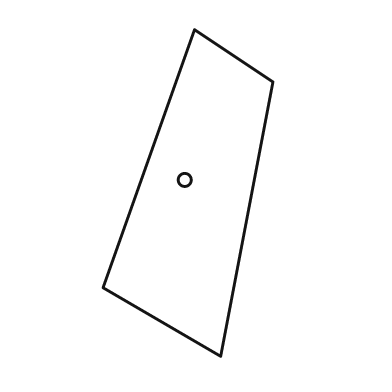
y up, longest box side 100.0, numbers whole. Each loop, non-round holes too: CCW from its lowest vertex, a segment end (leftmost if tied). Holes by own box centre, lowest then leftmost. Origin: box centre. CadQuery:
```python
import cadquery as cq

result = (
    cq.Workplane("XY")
    .moveTo(10.0, -50.0)
    .lineTo(26.0, 34.0)
    .lineTo(2.0, 50.0)
    .lineTo(-26.0, -29.0)
    .close()
    .moveTo(-1.0, 4.0)
    .circle(2.0)
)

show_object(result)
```